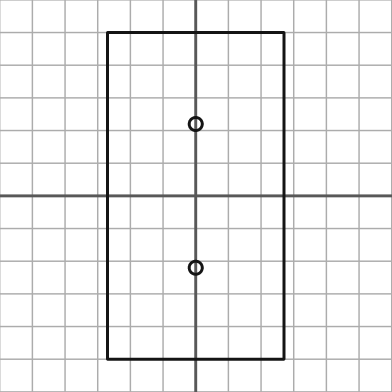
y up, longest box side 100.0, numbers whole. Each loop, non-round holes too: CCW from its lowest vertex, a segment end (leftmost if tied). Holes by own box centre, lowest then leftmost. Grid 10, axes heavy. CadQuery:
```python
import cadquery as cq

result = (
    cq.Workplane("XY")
    .moveTo(-27.0, -50.0)
    .lineTo(27.0, -50.0)
    .lineTo(27.0, 50.0)
    .lineTo(-27.0, 50.0)
    .close()
    .moveTo(0.0, -22.0)
    .circle(2.0)
    .moveTo(0.0, 22.0)
    .circle(2.0)
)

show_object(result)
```